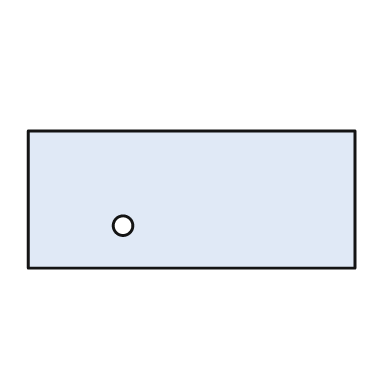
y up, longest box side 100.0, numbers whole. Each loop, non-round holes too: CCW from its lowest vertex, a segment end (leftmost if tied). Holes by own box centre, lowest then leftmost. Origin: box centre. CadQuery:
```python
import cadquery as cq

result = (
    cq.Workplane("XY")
    .moveTo(-50.0, -21.0)
    .lineTo(50.0, -21.0)
    .lineTo(50.0, 21.0)
    .lineTo(-50.0, 21.0)
    .close()
    .moveTo(-21.0, -8.0)
    .circle(3.0)
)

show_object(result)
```